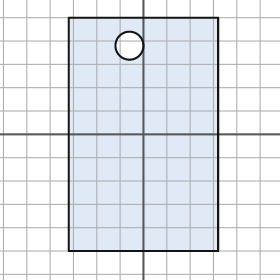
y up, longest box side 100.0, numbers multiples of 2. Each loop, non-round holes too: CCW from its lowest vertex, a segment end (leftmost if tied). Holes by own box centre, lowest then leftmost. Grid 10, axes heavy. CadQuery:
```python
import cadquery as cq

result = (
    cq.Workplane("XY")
    .moveTo(-32.0, -50.0)
    .lineTo(32.0, -50.0)
    .lineTo(32.0, 50.0)
    .lineTo(-32.0, 50.0)
    .close()
    .moveTo(-6.0, 38.0)
    .circle(6.0)
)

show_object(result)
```